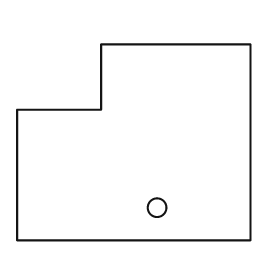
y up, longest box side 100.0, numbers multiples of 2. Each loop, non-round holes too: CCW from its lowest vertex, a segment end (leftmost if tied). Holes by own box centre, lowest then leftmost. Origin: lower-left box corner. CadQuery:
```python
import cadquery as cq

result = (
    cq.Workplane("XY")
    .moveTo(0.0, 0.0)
    .lineTo(100.0, 0.0)
    .lineTo(100.0, 84.0)
    .lineTo(36.0, 84.0)
    .lineTo(36.0, 56.0)
    .lineTo(0.0, 56.0)
    .close()
    .moveTo(60.0, 14.0)
    .circle(4.0)
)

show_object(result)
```